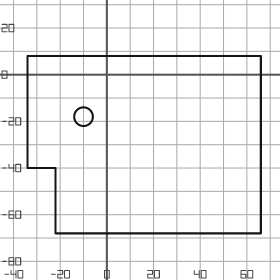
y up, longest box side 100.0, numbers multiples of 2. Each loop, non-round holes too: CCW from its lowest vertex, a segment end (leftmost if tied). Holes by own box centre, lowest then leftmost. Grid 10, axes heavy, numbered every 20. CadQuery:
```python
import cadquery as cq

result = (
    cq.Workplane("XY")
    .moveTo(-22.0, -68.0)
    .lineTo(66.0, -68.0)
    .lineTo(66.0, 8.0)
    .lineTo(-34.0, 8.0)
    .lineTo(-34.0, -40.0)
    .lineTo(-22.0, -40.0)
    .close()
    .moveTo(-10.0, -18.0)
    .circle(4.0)
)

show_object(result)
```